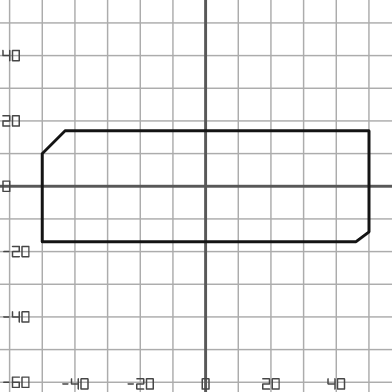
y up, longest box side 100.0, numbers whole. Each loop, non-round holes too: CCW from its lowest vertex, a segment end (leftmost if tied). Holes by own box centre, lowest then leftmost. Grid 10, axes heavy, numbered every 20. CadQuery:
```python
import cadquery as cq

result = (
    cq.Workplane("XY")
    .moveTo(-50.0, -17.0)
    .lineTo(46.0, -17.0)
    .lineTo(50.0, -14.0)
    .lineTo(50.0, 17.0)
    .lineTo(-43.0, 17.0)
    .lineTo(-50.0, 10.0)
    .close()
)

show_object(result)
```